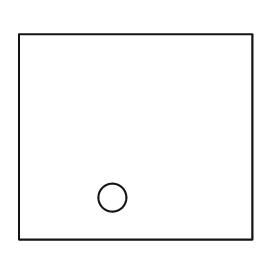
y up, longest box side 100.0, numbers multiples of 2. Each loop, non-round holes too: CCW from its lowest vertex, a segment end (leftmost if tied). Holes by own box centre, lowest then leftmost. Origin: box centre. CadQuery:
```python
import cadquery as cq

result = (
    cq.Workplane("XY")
    .moveTo(-50.0, -44.0)
    .lineTo(50.0, -44.0)
    .lineTo(50.0, 44.0)
    .lineTo(-50.0, 44.0)
    .close()
    .moveTo(-10.0, -26.0)
    .circle(6.0)
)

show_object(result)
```